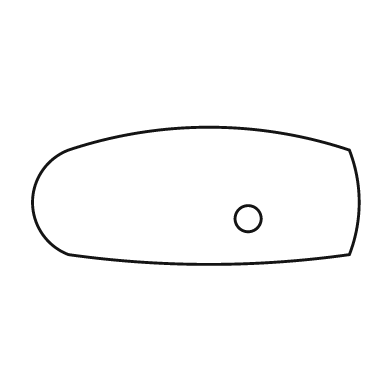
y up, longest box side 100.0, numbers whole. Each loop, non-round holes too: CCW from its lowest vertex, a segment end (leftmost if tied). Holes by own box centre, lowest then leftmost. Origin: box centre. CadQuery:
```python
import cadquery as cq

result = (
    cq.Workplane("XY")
    .moveTo(-39.0, -18.0)
    .threePointArc((4.0, -21.0), (47.0, -18.0))
    .threePointArc((50.0, -2.0), (47.0, 14.0))
    .threePointArc((4.0, 21.0), (-39.0, 14.0))
    .threePointArc((-50.0, -2.0), (-39.0, -18.0))
    .close()
    .moveTo(16.0, -7.0)
    .circle(4.0)
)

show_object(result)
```